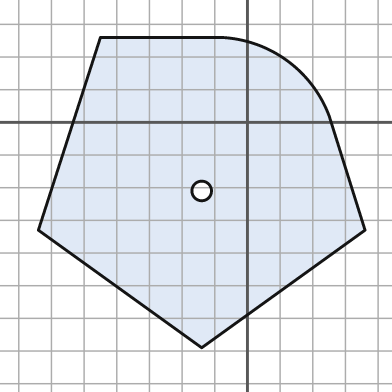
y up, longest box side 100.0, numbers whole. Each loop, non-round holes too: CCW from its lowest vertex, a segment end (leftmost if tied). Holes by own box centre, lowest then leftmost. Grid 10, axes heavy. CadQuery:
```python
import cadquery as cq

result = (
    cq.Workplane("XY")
    .moveTo(-14.0, -69.0)
    .lineTo(36.0, -33.0)
    .lineTo(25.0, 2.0)
    .threePointArc((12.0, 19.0), (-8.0, 26.0))
    .lineTo(-45.0, 26.0)
    .lineTo(-64.0, -33.0)
    .close()
    .moveTo(-14.0, -21.0)
    .circle(3.0)
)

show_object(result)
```